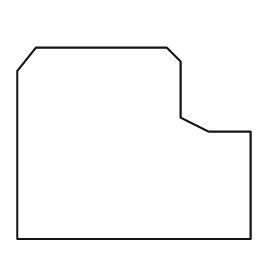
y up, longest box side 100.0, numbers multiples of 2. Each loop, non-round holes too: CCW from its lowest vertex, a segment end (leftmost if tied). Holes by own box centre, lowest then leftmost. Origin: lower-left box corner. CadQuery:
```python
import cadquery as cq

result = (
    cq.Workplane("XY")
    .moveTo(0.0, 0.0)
    .lineTo(100.0, 0.0)
    .lineTo(100.0, 46.0)
    .lineTo(82.0, 46.0)
    .lineTo(70.0, 52.0)
    .lineTo(70.0, 76.0)
    .lineTo(64.0, 82.0)
    .lineTo(8.0, 82.0)
    .lineTo(0.0, 72.0)
    .close()
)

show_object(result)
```